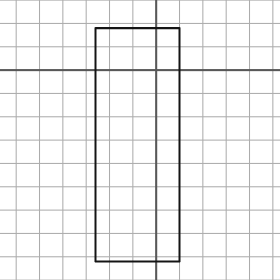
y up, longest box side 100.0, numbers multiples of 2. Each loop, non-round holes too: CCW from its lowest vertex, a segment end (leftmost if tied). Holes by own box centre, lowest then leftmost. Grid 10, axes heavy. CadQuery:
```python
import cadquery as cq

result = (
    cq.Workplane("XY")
    .moveTo(-26.0, -82.0)
    .lineTo(10.0, -82.0)
    .lineTo(10.0, 18.0)
    .lineTo(-26.0, 18.0)
    .close()
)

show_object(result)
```